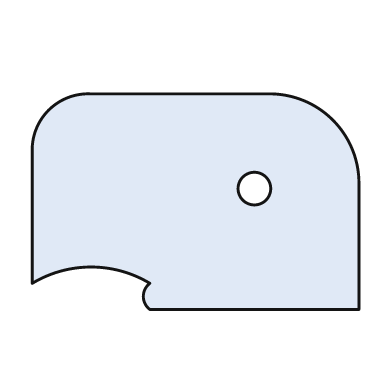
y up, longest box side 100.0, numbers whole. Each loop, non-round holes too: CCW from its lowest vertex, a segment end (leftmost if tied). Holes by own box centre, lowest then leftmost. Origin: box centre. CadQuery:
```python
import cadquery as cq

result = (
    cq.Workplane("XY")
    .moveTo(-14.0, -33.0)
    .lineTo(50.0, -33.0)
    .lineTo(50.0, 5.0)
    .threePointArc((42.0, 25.0), (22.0, 33.0))
    .lineTo(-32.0, 33.0)
    .threePointArc((-45.0, 28.0), (-50.0, 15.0))
    .lineTo(-50.0, -25.0)
    .threePointArc((-32.0, -20.0), (-14.0, -25.0))
    .threePointArc((-16.0, -29.0), (-14.0, -33.0))
    .close()
    .moveTo(18.0, 4.0)
    .circle(5.0)
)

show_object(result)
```